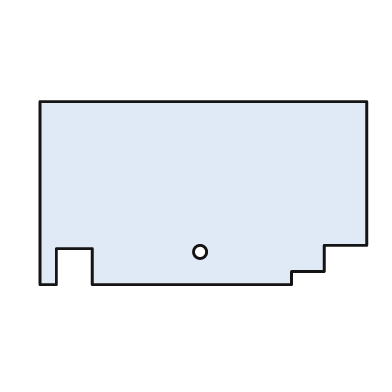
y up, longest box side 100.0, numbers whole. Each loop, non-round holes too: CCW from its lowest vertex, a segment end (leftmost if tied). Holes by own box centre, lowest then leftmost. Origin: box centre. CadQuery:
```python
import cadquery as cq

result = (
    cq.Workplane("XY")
    .moveTo(-50.0, -28.0)
    .lineTo(-45.0, -28.0)
    .lineTo(-45.0, -17.0)
    .lineTo(-34.0, -17.0)
    .lineTo(-34.0, -28.0)
    .lineTo(27.0, -28.0)
    .lineTo(27.0, -24.0)
    .lineTo(37.0, -24.0)
    .lineTo(37.0, -16.0)
    .lineTo(50.0, -16.0)
    .lineTo(50.0, 28.0)
    .lineTo(-50.0, 28.0)
    .close()
    .moveTo(-1.0, -18.0)
    .circle(2.0)
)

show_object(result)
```